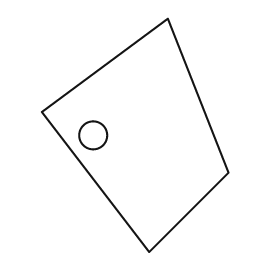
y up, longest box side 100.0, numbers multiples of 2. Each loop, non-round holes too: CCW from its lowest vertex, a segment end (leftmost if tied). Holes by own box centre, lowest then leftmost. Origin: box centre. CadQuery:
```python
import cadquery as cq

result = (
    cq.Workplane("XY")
    .moveTo(6.0, -50.0)
    .lineTo(40.0, -16.0)
    .lineTo(14.0, 50.0)
    .lineTo(-40.0, 10.0)
    .close()
    .moveTo(-18.0, 0.0)
    .circle(6.0)
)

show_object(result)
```